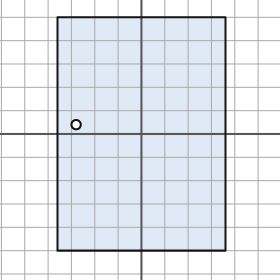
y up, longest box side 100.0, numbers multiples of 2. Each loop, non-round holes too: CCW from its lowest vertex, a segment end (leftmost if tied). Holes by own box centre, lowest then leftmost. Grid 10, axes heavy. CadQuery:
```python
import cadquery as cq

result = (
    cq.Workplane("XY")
    .moveTo(-36.0, -50.0)
    .lineTo(36.0, -50.0)
    .lineTo(36.0, 50.0)
    .lineTo(-36.0, 50.0)
    .close()
    .moveTo(-28.0, 4.0)
    .circle(2.0)
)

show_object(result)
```